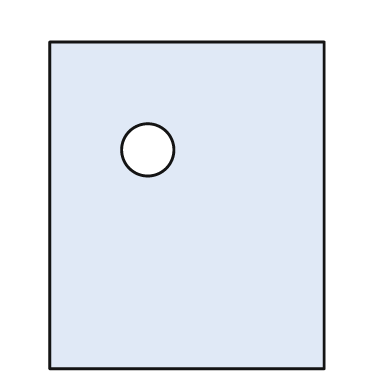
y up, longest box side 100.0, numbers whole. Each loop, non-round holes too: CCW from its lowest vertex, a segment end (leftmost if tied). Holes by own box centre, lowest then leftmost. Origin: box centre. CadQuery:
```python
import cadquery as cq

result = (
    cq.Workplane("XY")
    .moveTo(-42.0, -50.0)
    .lineTo(42.0, -50.0)
    .lineTo(42.0, 50.0)
    .lineTo(-42.0, 50.0)
    .close()
    .moveTo(-12.0, 17.0)
    .circle(8.0)
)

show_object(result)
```